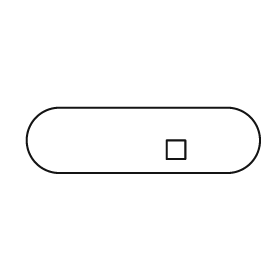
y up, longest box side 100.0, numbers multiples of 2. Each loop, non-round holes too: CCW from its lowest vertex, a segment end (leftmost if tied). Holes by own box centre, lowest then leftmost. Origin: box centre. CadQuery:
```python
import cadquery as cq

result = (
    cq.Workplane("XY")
    .moveTo(-36.0, -14.0)
    .lineTo(36.0, -14.0)
    .threePointArc((50.0, 0.0), (36.0, 14.0))
    .lineTo(-36.0, 14.0)
    .threePointArc((-50.0, 0.0), (-36.0, -14.0))
    .close()
    .moveTo(10.0, -8.0)
    .lineTo(18.0, -8.0)
    .lineTo(18.0, 0.0)
    .lineTo(10.0, 0.0)
    .close()
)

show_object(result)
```